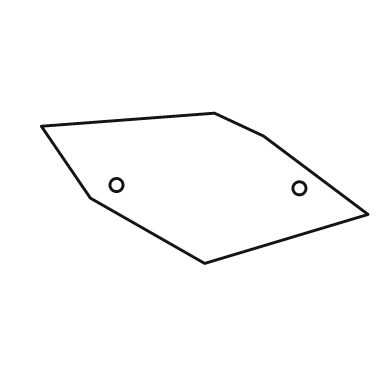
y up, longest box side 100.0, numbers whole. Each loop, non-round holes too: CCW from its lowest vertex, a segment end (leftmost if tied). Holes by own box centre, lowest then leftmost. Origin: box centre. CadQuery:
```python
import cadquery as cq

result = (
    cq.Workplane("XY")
    .moveTo(0.0, -23.0)
    .lineTo(50.0, -8.0)
    .lineTo(18.0, 16.0)
    .lineTo(3.0, 23.0)
    .lineTo(-50.0, 19.0)
    .lineTo(-35.0, -3.0)
    .close()
    .moveTo(29.0, 0.0)
    .circle(2.0)
    .moveTo(-27.0, 1.0)
    .circle(2.0)
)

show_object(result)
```